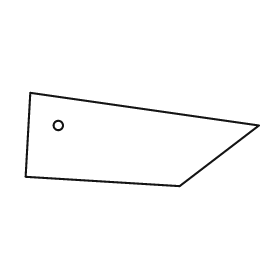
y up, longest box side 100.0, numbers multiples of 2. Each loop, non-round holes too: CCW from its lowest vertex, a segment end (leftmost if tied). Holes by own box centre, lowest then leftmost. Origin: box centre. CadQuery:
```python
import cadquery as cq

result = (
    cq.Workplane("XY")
    .moveTo(16.0, -20.0)
    .lineTo(50.0, 6.0)
    .lineTo(-48.0, 20.0)
    .lineTo(-50.0, -16.0)
    .close()
    .moveTo(-36.0, 6.0)
    .circle(2.0)
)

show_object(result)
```